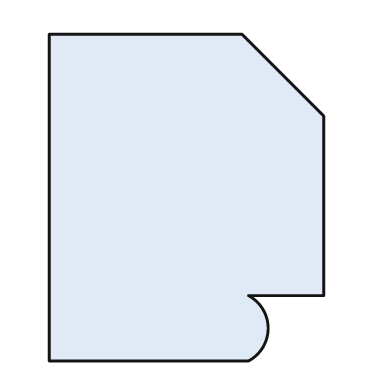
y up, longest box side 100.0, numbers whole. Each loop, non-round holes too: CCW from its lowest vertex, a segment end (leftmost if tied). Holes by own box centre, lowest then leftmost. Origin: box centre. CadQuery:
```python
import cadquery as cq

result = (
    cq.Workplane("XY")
    .moveTo(-42.0, -50.0)
    .lineTo(19.0, -50.0)
    .threePointArc((25.0, -40.0), (19.0, -30.0))
    .lineTo(42.0, -30.0)
    .lineTo(42.0, 25.0)
    .lineTo(17.0, 50.0)
    .lineTo(-42.0, 50.0)
    .close()
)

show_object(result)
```